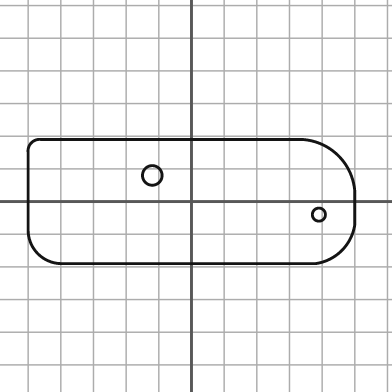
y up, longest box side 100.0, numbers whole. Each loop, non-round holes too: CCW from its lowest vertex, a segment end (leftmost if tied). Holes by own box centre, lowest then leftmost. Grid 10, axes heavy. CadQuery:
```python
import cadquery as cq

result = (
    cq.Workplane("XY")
    .moveTo(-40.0, -19.0)
    .lineTo(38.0, -19.0)
    .threePointArc((46.0, -15.0), (50.0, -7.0))
    .lineTo(50.0, 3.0)
    .threePointArc((45.0, 14.0), (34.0, 19.0))
    .lineTo(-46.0, 19.0)
    .threePointArc((-49.0, 18.0), (-50.0, 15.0))
    .lineTo(-50.0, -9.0)
    .threePointArc((-47.0, -16.0), (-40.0, -19.0))
    .close()
    .moveTo(39.0, -4.0)
    .circle(2.0)
    .moveTo(-12.0, 8.0)
    .circle(3.0)
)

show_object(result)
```